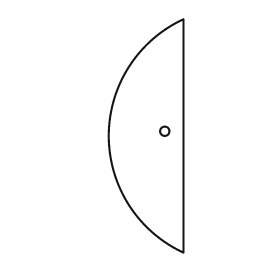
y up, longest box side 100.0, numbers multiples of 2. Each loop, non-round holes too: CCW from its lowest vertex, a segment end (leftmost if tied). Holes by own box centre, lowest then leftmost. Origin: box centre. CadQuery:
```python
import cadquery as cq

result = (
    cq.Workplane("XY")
    .moveTo(16.0, -50.0)
    .lineTo(16.0, 50.0)
    .threePointArc((-16.0, 0.0), (16.0, -50.0))
    .close()
    .moveTo(8.0, 2.0)
    .circle(2.0)
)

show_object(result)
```